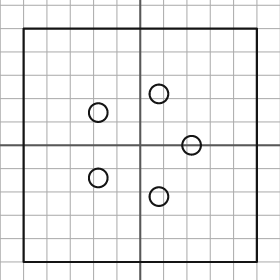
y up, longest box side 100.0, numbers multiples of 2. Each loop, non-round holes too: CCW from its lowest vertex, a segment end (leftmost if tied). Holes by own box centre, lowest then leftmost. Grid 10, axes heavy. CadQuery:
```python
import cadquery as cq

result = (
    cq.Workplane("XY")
    .moveTo(-50.0, -50.0)
    .lineTo(50.0, -50.0)
    .lineTo(50.0, 50.0)
    .lineTo(-50.0, 50.0)
    .close()
    .moveTo(8.0, -22.0)
    .circle(4.0)
    .moveTo(-18.0, -14.0)
    .circle(4.0)
    .moveTo(22.0, 0.0)
    .circle(4.0)
    .moveTo(-18.0, 14.0)
    .circle(4.0)
    .moveTo(8.0, 22.0)
    .circle(4.0)
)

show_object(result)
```